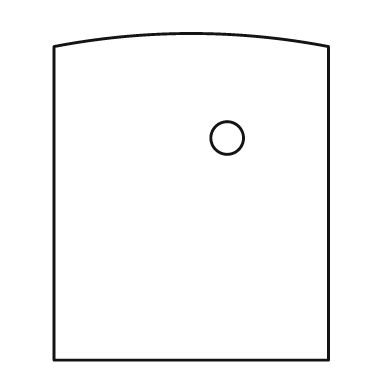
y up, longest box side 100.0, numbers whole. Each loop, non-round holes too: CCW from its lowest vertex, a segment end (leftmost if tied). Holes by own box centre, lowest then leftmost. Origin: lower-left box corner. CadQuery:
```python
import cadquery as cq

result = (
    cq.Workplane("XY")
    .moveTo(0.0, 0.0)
    .lineTo(84.0, 0.0)
    .lineTo(84.0, 96.0)
    .threePointArc((42.0, 100.0), (0.0, 96.0))
    .close()
    .moveTo(53.0, 68.0)
    .circle(5.0)
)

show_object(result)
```